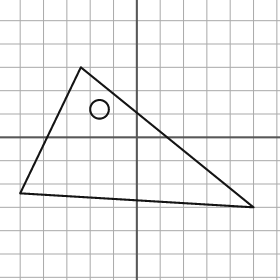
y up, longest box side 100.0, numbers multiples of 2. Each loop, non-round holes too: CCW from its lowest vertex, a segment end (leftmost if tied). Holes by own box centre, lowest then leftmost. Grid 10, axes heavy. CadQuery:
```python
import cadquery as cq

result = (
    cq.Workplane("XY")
    .moveTo(50.0, -30.0)
    .lineTo(-24.0, 30.0)
    .lineTo(-50.0, -24.0)
    .close()
    .moveTo(-16.0, 12.0)
    .circle(4.0)
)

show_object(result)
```